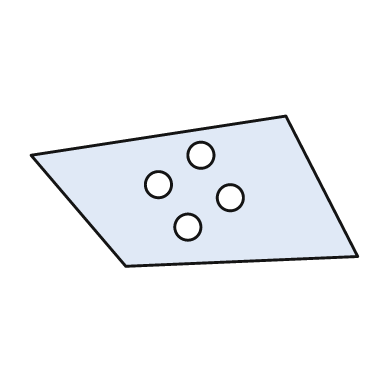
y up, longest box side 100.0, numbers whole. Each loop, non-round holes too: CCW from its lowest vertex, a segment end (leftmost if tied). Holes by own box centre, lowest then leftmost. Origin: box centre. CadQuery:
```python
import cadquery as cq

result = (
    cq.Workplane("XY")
    .moveTo(-21.0, -23.0)
    .lineTo(50.0, -20.0)
    .lineTo(28.0, 23.0)
    .lineTo(-50.0, 11.0)
    .close()
    .moveTo(-2.0, -11.0)
    .circle(4.0)
    .moveTo(11.0, -2.0)
    .circle(4.0)
    .moveTo(-11.0, 2.0)
    .circle(4.0)
    .moveTo(2.0, 11.0)
    .circle(4.0)
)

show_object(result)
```